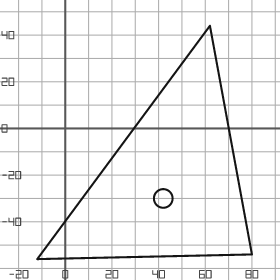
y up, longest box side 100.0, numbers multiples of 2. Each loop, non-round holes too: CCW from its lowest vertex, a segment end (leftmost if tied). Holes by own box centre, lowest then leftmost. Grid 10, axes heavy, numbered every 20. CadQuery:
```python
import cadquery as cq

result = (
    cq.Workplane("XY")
    .moveTo(-12.0, -56.0)
    .lineTo(80.0, -54.0)
    .lineTo(62.0, 44.0)
    .close()
    .moveTo(42.0, -30.0)
    .circle(4.0)
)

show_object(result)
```